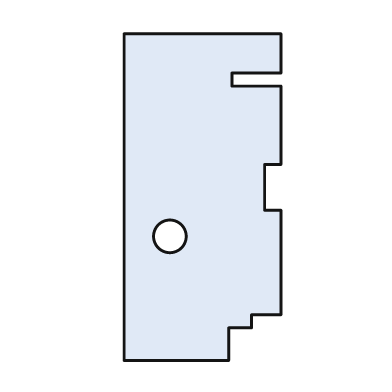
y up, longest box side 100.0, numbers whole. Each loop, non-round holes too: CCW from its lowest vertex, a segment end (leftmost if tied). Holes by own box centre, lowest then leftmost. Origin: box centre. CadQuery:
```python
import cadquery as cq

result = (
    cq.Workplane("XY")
    .moveTo(-24.0, -50.0)
    .lineTo(8.0, -50.0)
    .lineTo(8.0, -40.0)
    .lineTo(15.0, -40.0)
    .lineTo(15.0, -36.0)
    .lineTo(24.0, -36.0)
    .lineTo(24.0, -4.0)
    .lineTo(19.0, -4.0)
    .lineTo(19.0, 10.0)
    .lineTo(24.0, 10.0)
    .lineTo(24.0, 34.0)
    .lineTo(9.0, 34.0)
    .lineTo(9.0, 38.0)
    .lineTo(24.0, 38.0)
    .lineTo(24.0, 50.0)
    .lineTo(-24.0, 50.0)
    .close()
    .moveTo(-10.0, -12.0)
    .circle(5.0)
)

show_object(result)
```